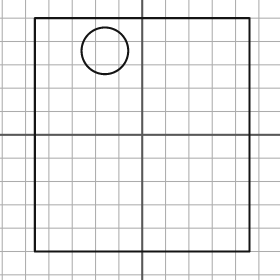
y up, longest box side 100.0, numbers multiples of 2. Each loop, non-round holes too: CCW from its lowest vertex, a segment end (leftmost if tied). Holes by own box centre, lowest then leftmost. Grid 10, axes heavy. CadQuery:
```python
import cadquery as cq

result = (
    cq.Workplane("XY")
    .moveTo(-46.0, -50.0)
    .lineTo(46.0, -50.0)
    .lineTo(46.0, 50.0)
    .lineTo(-46.0, 50.0)
    .close()
    .moveTo(-16.0, 36.0)
    .circle(10.0)
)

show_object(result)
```